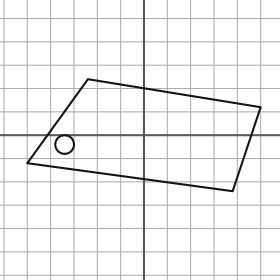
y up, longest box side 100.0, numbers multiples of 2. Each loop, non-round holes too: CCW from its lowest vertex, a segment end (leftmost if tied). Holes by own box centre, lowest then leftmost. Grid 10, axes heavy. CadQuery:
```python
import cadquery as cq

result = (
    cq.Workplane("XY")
    .moveTo(38.0, -24.0)
    .lineTo(50.0, 12.0)
    .lineTo(-24.0, 24.0)
    .lineTo(-50.0, -12.0)
    .close()
    .moveTo(-34.0, -4.0)
    .circle(4.0)
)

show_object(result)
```